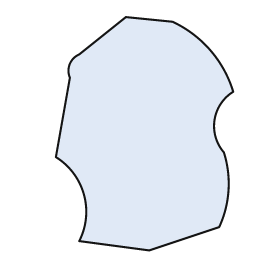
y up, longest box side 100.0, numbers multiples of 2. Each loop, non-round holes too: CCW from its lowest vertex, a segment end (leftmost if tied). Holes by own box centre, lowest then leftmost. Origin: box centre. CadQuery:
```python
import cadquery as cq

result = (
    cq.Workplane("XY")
    .moveTo(2.0, -50.0)
    .lineTo(32.0, -40.0)
    .threePointArc((36.0, -24.0), (34.0, -8.0))
    .threePointArc((30.0, 6.0), (38.0, 18.0))
    .threePointArc((28.0, 36.0), (12.0, 48.0))
    .lineTo(-8.0, 50.0)
    .lineTo(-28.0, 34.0)
    .threePointArc((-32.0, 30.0), (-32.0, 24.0))
    .lineTo(-38.0, -10.0)
    .threePointArc((-26.0, -26.0), (-28.0, -46.0))
    .close()
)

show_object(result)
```